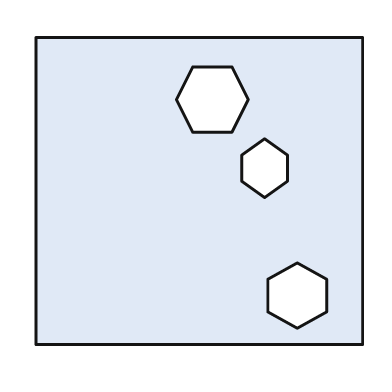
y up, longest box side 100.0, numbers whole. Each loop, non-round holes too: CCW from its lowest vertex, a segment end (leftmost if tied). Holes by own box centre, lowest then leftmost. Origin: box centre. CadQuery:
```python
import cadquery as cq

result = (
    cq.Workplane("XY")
    .moveTo(-50.0, -47.0)
    .lineTo(50.0, -47.0)
    .lineTo(50.0, 47.0)
    .lineTo(-50.0, 47.0)
    .close()
    .moveTo(30.0, -42.0)
    .lineTo(39.0, -37.0)
    .lineTo(39.0, -27.0)
    .lineTo(30.0, -22.0)
    .lineTo(21.0, -27.0)
    .lineTo(21.0, -37.0)
    .close()
    .moveTo(20.0, -2.0)
    .lineTo(27.0, 3.0)
    .lineTo(27.0, 11.0)
    .lineTo(20.0, 16.0)
    .lineTo(13.0, 11.0)
    .lineTo(13.0, 3.0)
    .close()
    .moveTo(-2.0, 18.0)
    .lineTo(10.0, 18.0)
    .lineTo(15.0, 28.0)
    .lineTo(10.0, 38.0)
    .lineTo(-2.0, 38.0)
    .lineTo(-7.0, 28.0)
    .close()
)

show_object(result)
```